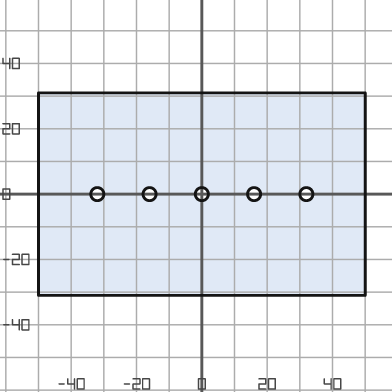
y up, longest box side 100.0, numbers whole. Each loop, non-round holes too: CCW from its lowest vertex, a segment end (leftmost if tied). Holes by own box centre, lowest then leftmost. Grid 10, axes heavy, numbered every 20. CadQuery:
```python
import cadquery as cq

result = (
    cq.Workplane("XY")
    .moveTo(-50.0, -31.0)
    .lineTo(50.0, -31.0)
    .lineTo(50.0, 31.0)
    .lineTo(-50.0, 31.0)
    .close()
    .moveTo(-32.0, 0.0)
    .circle(2.0)
    .moveTo(-16.0, 0.0)
    .circle(2.0)
    .moveTo(0.0, 0.0)
    .circle(2.0)
    .moveTo(16.0, 0.0)
    .circle(2.0)
    .moveTo(32.0, 0.0)
    .circle(2.0)
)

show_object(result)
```